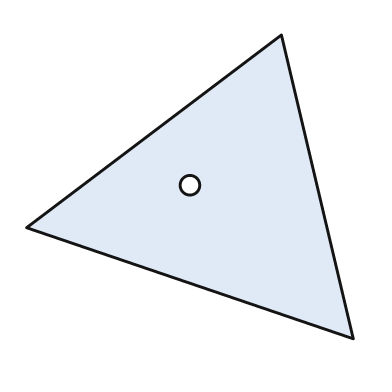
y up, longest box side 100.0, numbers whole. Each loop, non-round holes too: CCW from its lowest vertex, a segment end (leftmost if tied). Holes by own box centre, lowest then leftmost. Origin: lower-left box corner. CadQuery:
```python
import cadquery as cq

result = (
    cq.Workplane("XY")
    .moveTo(100.0, 0.0)
    .lineTo(78.0, 93.0)
    .lineTo(0.0, 34.0)
    .close()
    .moveTo(50.0, 47.0)
    .circle(3.0)
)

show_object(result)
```